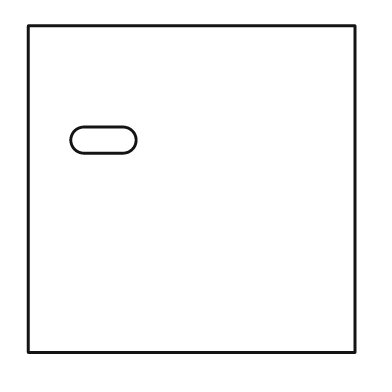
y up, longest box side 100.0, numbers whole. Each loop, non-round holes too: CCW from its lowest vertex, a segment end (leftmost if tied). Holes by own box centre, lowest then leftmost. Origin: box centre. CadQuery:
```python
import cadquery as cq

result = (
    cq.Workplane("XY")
    .moveTo(-50.0, -50.0)
    .lineTo(50.0, -50.0)
    .lineTo(50.0, 50.0)
    .lineTo(-50.0, 50.0)
    .close()
    .moveTo(-33.0, 11.0)
    .lineTo(-21.0, 11.0)
    .threePointArc((-17.0, 15.0), (-21.0, 19.0))
    .lineTo(-33.0, 19.0)
    .threePointArc((-37.0, 15.0), (-33.0, 11.0))
    .close()
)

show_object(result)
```